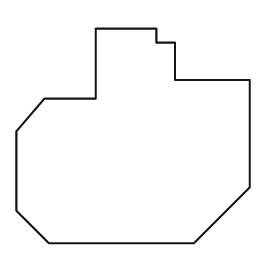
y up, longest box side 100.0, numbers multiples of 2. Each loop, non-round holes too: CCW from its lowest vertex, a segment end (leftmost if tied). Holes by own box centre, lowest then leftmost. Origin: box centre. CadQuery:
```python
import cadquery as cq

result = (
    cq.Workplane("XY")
    .moveTo(-36.0, -46.0)
    .lineTo(26.0, -46.0)
    .lineTo(50.0, -22.0)
    .lineTo(50.0, 24.0)
    .lineTo(18.0, 24.0)
    .lineTo(18.0, 40.0)
    .lineTo(10.0, 40.0)
    .lineTo(10.0, 46.0)
    .lineTo(-16.0, 46.0)
    .lineTo(-16.0, 16.0)
    .lineTo(-38.0, 16.0)
    .lineTo(-50.0, 2.0)
    .lineTo(-50.0, -32.0)
    .close()
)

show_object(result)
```